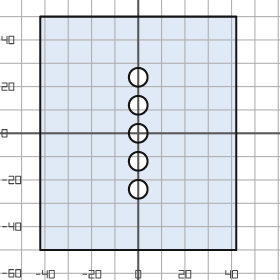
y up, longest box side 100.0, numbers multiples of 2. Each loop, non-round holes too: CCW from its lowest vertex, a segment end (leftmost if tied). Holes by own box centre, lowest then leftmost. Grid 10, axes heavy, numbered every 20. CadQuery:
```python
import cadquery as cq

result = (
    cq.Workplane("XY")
    .moveTo(-42.0, -50.0)
    .lineTo(42.0, -50.0)
    .lineTo(42.0, 50.0)
    .lineTo(-42.0, 50.0)
    .close()
    .moveTo(0.0, -24.0)
    .circle(4.0)
    .moveTo(0.0, -12.0)
    .circle(4.0)
    .moveTo(0.0, 0.0)
    .circle(4.0)
    .moveTo(0.0, 12.0)
    .circle(4.0)
    .moveTo(0.0, 24.0)
    .circle(4.0)
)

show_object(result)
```